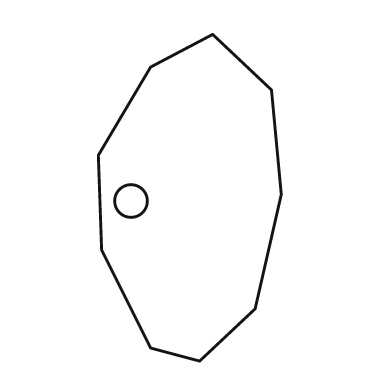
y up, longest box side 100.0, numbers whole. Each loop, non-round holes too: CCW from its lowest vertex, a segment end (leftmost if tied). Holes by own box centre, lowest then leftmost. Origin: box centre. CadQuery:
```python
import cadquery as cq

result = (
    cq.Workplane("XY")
    .moveTo(3.0, -50.0)
    .lineTo(20.0, -34.0)
    .lineTo(28.0, 1.0)
    .lineTo(25.0, 33.0)
    .lineTo(7.0, 50.0)
    .lineTo(-12.0, 40.0)
    .lineTo(-28.0, 13.0)
    .lineTo(-27.0, -16.0)
    .lineTo(-12.0, -46.0)
    .close()
    .moveTo(-18.0, -1.0)
    .circle(5.0)
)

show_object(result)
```